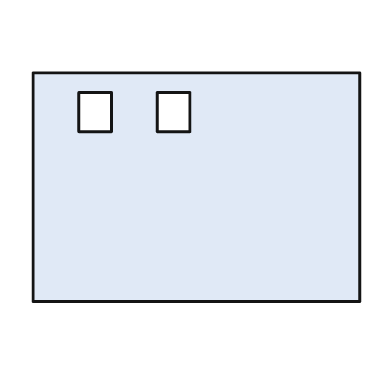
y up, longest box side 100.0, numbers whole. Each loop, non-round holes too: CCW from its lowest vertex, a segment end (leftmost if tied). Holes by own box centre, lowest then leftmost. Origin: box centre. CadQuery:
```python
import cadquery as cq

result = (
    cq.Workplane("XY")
    .moveTo(-50.0, -35.0)
    .lineTo(50.0, -35.0)
    .lineTo(50.0, 35.0)
    .lineTo(-50.0, 35.0)
    .close()
    .moveTo(-36.0, 17.0)
    .lineTo(-26.0, 17.0)
    .lineTo(-26.0, 29.0)
    .lineTo(-36.0, 29.0)
    .close()
    .moveTo(-12.0, 17.0)
    .lineTo(-2.0, 17.0)
    .lineTo(-2.0, 29.0)
    .lineTo(-12.0, 29.0)
    .close()
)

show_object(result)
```